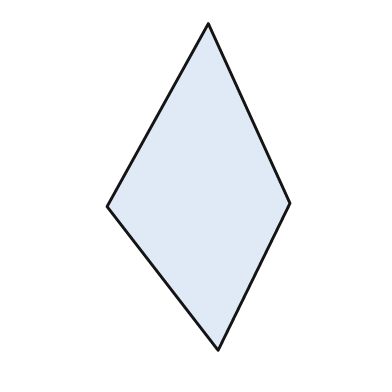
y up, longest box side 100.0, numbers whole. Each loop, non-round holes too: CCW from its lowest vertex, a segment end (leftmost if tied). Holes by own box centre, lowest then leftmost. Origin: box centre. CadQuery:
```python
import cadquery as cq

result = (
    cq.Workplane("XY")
    .moveTo(6.0, -50.0)
    .lineTo(28.0, -5.0)
    .lineTo(3.0, 50.0)
    .lineTo(-28.0, -6.0)
    .close()
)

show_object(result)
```